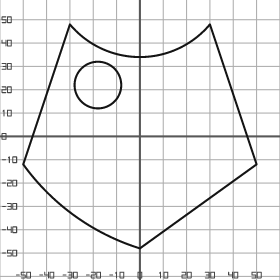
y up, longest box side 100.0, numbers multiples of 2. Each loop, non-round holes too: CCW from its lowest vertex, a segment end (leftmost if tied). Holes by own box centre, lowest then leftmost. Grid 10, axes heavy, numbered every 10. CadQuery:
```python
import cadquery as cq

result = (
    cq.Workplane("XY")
    .moveTo(0.0, -48.0)
    .lineTo(50.0, -12.0)
    .lineTo(30.0, 48.0)
    .threePointArc((0.0, 34.0), (-30.0, 48.0))
    .lineTo(-50.0, -12.0)
    .threePointArc((-28.0, -34.0), (0.0, -48.0))
    .close()
    .moveTo(-18.0, 22.0)
    .circle(10.0)
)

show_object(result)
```